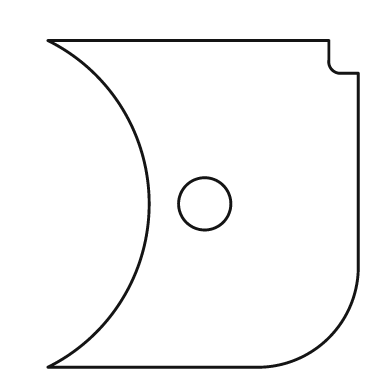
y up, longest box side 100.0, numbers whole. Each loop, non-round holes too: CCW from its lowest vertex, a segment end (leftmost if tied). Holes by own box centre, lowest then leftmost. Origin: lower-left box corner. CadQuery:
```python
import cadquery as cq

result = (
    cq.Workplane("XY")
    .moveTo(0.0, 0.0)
    .lineTo(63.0, 0.0)
    .threePointArc((86.0, 9.0), (95.0, 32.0))
    .lineTo(95.0, 90.0)
    .lineTo(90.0, 90.0)
    .threePointArc((87.0, 91.0), (86.0, 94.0))
    .lineTo(86.0, 100.0)
    .lineTo(0.0, 100.0)
    .threePointArc((31.0, 50.0), (0.0, 0.0))
    .close()
    .moveTo(48.0, 50.0)
    .circle(8.0)
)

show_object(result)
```